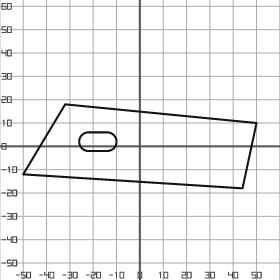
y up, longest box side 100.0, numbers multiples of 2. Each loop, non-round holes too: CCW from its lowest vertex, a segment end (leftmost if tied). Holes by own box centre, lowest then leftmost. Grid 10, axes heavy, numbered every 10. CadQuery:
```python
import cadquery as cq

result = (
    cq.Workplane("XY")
    .moveTo(44.0, -18.0)
    .lineTo(50.0, 10.0)
    .lineTo(-32.0, 18.0)
    .lineTo(-50.0, -12.0)
    .close()
    .moveTo(-22.0, -2.0)
    .lineTo(-14.0, -2.0)
    .threePointArc((-10.0, 2.0), (-14.0, 6.0))
    .lineTo(-22.0, 6.0)
    .threePointArc((-26.0, 2.0), (-22.0, -2.0))
    .close()
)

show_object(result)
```